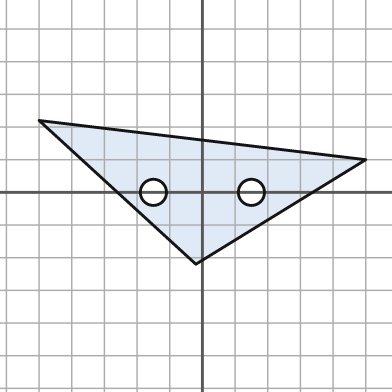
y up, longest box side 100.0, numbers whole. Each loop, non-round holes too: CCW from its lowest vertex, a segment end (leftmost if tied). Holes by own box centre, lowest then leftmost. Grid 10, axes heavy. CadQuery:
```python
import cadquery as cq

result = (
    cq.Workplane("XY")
    .moveTo(-2.0, -22.0)
    .lineTo(50.0, 10.0)
    .lineTo(-50.0, 22.0)
    .close()
    .moveTo(-15.0, 0.0)
    .circle(4.0)
    .moveTo(15.0, 0.0)
    .circle(4.0)
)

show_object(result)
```